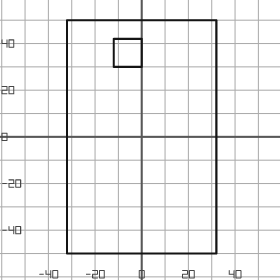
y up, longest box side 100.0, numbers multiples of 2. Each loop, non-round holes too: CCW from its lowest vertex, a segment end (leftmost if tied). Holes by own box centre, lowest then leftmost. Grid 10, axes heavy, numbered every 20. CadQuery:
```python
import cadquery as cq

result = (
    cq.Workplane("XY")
    .moveTo(-32.0, -50.0)
    .lineTo(32.0, -50.0)
    .lineTo(32.0, 50.0)
    .lineTo(-32.0, 50.0)
    .close()
    .moveTo(-12.0, 30.0)
    .lineTo(0.0, 30.0)
    .lineTo(0.0, 42.0)
    .lineTo(-12.0, 42.0)
    .close()
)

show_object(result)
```